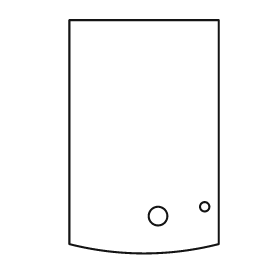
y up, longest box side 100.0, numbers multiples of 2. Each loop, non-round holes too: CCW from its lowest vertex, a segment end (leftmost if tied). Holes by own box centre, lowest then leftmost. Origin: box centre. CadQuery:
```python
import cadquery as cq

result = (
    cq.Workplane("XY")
    .moveTo(-32.0, -46.0)
    .threePointArc((0.0, -50.0), (32.0, -46.0))
    .lineTo(32.0, 50.0)
    .lineTo(-32.0, 50.0)
    .close()
    .moveTo(6.0, -34.0)
    .circle(4.0)
    .moveTo(26.0, -30.0)
    .circle(2.0)
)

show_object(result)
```